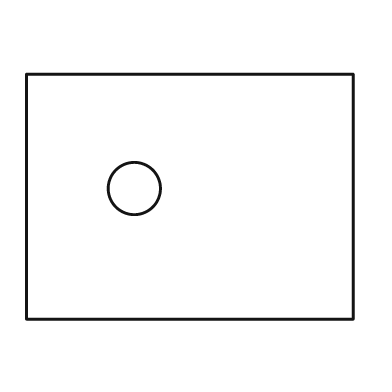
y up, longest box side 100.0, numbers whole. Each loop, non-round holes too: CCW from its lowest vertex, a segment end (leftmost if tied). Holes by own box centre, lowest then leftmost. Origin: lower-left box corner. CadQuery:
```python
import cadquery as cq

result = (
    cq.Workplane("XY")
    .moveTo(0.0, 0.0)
    .lineTo(100.0, 0.0)
    .lineTo(100.0, 75.0)
    .lineTo(0.0, 75.0)
    .close()
    .moveTo(33.0, 40.0)
    .circle(8.0)
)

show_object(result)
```